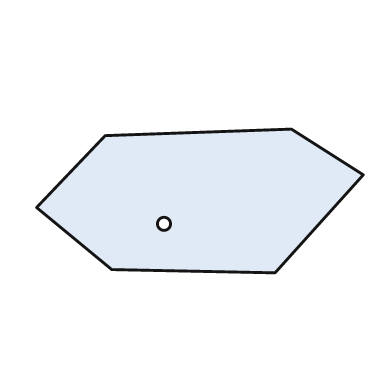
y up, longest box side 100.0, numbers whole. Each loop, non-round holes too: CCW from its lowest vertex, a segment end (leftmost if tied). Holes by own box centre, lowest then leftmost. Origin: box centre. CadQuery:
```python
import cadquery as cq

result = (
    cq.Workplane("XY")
    .moveTo(23.0, -22.0)
    .lineTo(50.0, 8.0)
    .lineTo(28.0, 22.0)
    .lineTo(-29.0, 20.0)
    .lineTo(-50.0, -2.0)
    .lineTo(-27.0, -21.0)
    .close()
    .moveTo(-11.0, -7.0)
    .circle(2.0)
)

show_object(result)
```